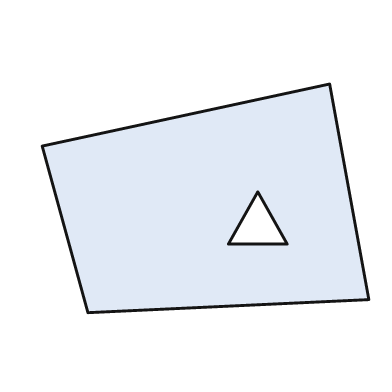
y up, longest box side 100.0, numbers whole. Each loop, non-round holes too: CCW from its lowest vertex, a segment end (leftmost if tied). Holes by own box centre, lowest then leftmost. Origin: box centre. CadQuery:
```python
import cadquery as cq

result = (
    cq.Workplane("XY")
    .moveTo(-36.0, -35.0)
    .lineTo(50.0, -31.0)
    .lineTo(38.0, 35.0)
    .lineTo(-50.0, 16.0)
    .close()
    .moveTo(7.0, -14.0)
    .lineTo(25.0, -14.0)
    .lineTo(16.0, 2.0)
    .close()
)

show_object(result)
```